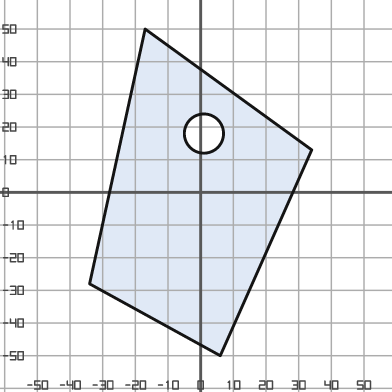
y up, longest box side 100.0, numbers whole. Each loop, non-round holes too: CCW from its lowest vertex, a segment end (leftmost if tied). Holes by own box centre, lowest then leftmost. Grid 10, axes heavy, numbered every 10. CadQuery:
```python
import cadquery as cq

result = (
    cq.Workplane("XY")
    .moveTo(6.0, -50.0)
    .lineTo(34.0, 13.0)
    .lineTo(-17.0, 50.0)
    .lineTo(-34.0, -28.0)
    .close()
    .moveTo(1.0, 18.0)
    .circle(6.0)
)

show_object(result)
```